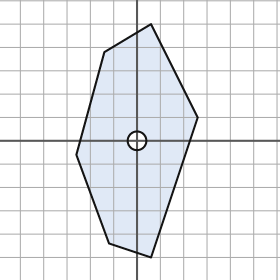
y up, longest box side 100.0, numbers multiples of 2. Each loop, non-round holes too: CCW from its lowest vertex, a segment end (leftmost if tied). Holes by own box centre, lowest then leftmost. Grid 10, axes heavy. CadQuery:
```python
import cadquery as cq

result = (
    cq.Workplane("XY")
    .moveTo(6.0, -50.0)
    .lineTo(26.0, 10.0)
    .lineTo(6.0, 50.0)
    .lineTo(-14.0, 38.0)
    .lineTo(-26.0, -6.0)
    .lineTo(-12.0, -44.0)
    .close()
    .moveTo(0.0, 0.0)
    .circle(4.0)
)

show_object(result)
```